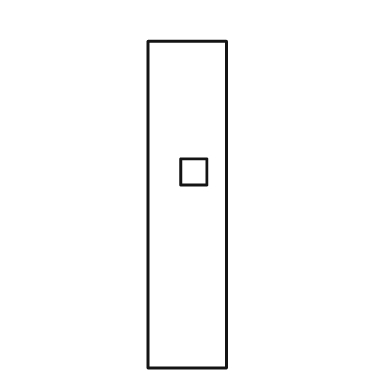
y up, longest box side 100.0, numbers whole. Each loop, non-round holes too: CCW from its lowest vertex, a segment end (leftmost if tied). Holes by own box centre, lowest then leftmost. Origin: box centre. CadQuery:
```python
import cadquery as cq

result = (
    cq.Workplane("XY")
    .moveTo(-12.0, -50.0)
    .lineTo(12.0, -50.0)
    .lineTo(12.0, 50.0)
    .lineTo(-12.0, 50.0)
    .close()
    .moveTo(-2.0, 6.0)
    .lineTo(6.0, 6.0)
    .lineTo(6.0, 14.0)
    .lineTo(-2.0, 14.0)
    .close()
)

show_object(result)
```